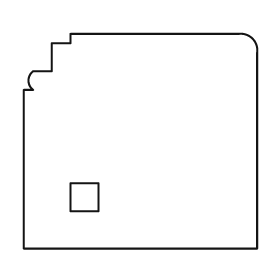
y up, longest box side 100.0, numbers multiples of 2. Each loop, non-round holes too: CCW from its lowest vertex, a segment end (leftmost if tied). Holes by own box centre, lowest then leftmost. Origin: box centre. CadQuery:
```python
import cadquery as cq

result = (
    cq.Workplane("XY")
    .moveTo(-50.0, -46.0)
    .lineTo(50.0, -46.0)
    .lineTo(50.0, 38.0)
    .threePointArc((48.0, 44.0), (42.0, 46.0))
    .lineTo(-30.0, 46.0)
    .lineTo(-30.0, 42.0)
    .lineTo(-38.0, 42.0)
    .lineTo(-38.0, 30.0)
    .lineTo(-46.0, 30.0)
    .threePointArc((-48.0, 26.0), (-46.0, 22.0))
    .lineTo(-50.0, 22.0)
    .close()
    .moveTo(-30.0, -30.0)
    .lineTo(-18.0, -30.0)
    .lineTo(-18.0, -18.0)
    .lineTo(-30.0, -18.0)
    .close()
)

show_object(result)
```